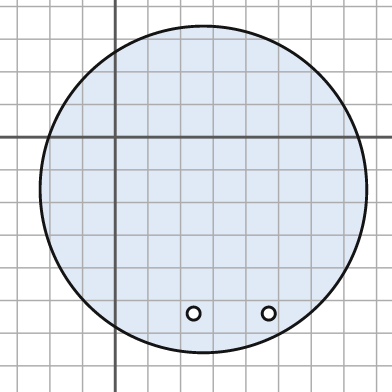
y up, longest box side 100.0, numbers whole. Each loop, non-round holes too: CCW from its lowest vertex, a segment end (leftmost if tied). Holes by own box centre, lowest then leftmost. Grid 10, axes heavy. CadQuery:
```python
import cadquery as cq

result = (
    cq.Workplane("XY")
    .moveTo(27.0, -16.0)
    .circle(50.0)
    .moveTo(24.0, -54.0)
    .circle(2.0)
    .moveTo(47.0, -54.0)
    .circle(2.0)
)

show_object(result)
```